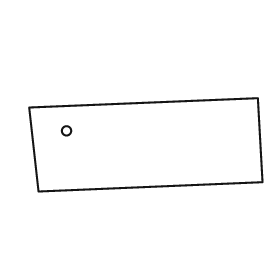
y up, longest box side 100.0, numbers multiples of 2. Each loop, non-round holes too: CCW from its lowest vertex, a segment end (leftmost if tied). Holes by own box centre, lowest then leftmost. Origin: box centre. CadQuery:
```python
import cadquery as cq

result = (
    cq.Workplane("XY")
    .moveTo(-46.0, -20.0)
    .lineTo(50.0, -16.0)
    .lineTo(48.0, 20.0)
    .lineTo(-50.0, 16.0)
    .close()
    .moveTo(-34.0, 6.0)
    .circle(2.0)
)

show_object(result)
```